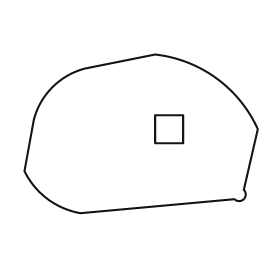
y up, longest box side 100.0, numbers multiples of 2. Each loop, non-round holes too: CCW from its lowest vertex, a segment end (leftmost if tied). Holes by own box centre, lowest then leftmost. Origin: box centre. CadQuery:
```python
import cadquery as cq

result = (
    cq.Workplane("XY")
    .moveTo(-26.0, -34.0)
    .lineTo(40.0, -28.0)
    .threePointArc((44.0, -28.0), (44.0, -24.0))
    .lineTo(50.0, 2.0)
    .threePointArc((32.0, 24.0), (6.0, 34.0))
    .lineTo(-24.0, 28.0)
    .threePointArc((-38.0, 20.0), (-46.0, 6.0))
    .lineTo(-50.0, -16.0)
    .threePointArc((-40.0, -28.0), (-26.0, -34.0))
    .close()
    .moveTo(6.0, -4.0)
    .lineTo(18.0, -4.0)
    .lineTo(18.0, 8.0)
    .lineTo(6.0, 8.0)
    .close()
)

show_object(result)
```